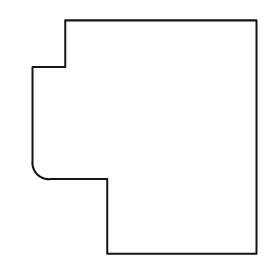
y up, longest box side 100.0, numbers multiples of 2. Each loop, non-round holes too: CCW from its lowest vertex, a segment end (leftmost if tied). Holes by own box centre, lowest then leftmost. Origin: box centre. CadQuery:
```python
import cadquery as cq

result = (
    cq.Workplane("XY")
    .moveTo(-16.0, -50.0)
    .lineTo(48.0, -50.0)
    .lineTo(48.0, 50.0)
    .lineTo(-34.0, 50.0)
    .lineTo(-34.0, 30.0)
    .lineTo(-48.0, 30.0)
    .lineTo(-48.0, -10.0)
    .threePointArc((-46.0, -16.0), (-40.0, -18.0))
    .lineTo(-16.0, -18.0)
    .close()
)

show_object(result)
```